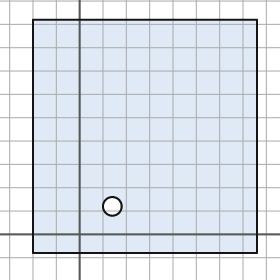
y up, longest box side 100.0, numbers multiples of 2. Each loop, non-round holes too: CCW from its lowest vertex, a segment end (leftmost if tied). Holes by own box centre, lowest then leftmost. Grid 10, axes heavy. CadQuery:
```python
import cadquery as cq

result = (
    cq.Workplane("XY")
    .moveTo(-20.0, -8.0)
    .lineTo(76.0, -8.0)
    .lineTo(76.0, 92.0)
    .lineTo(-20.0, 92.0)
    .close()
    .moveTo(14.0, 12.0)
    .circle(4.0)
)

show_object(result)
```